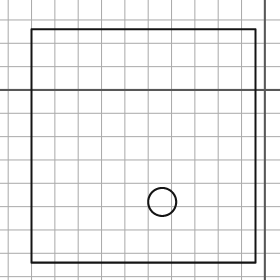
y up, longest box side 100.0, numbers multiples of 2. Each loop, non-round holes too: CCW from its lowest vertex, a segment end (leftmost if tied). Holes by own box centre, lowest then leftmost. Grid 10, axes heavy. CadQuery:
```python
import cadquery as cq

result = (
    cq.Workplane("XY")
    .moveTo(-100.0, -74.0)
    .lineTo(-4.0, -74.0)
    .lineTo(-4.0, 26.0)
    .lineTo(-100.0, 26.0)
    .close()
    .moveTo(-44.0, -48.0)
    .circle(6.0)
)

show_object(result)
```